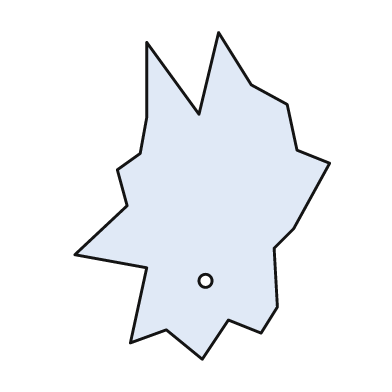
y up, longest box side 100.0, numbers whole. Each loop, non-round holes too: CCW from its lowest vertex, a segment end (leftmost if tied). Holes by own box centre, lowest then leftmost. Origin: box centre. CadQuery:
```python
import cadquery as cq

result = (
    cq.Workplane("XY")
    .moveTo(0.0, -50.0)
    .lineTo(8.0, -38.0)
    .lineTo(18.0, -42.0)
    .lineTo(23.0, -34.0)
    .lineTo(22.0, -16.0)
    .lineTo(28.0, -10.0)
    .lineTo(39.0, 10.0)
    .lineTo(29.0, 14.0)
    .lineTo(26.0, 28.0)
    .lineTo(15.0, 34.0)
    .lineTo(5.0, 50.0)
    .lineTo(-1.0, 25.0)
    .lineTo(-17.0, 47.0)
    .lineTo(-17.0, 24.0)
    .lineTo(-19.0, 13.0)
    .lineTo(-26.0, 8.0)
    .lineTo(-23.0, -3.0)
    .lineTo(-39.0, -18.0)
    .lineTo(-17.0, -22.0)
    .lineTo(-22.0, -45.0)
    .lineTo(-11.0, -41.0)
    .close()
    .moveTo(1.0, -26.0)
    .circle(2.0)
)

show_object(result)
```